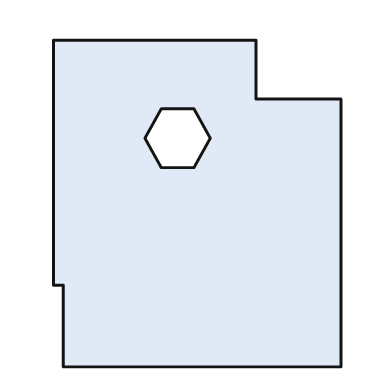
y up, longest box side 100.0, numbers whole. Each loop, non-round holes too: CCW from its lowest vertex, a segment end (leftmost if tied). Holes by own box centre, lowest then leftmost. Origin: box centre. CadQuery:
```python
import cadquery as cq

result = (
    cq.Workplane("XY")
    .moveTo(-41.0, -50.0)
    .lineTo(44.0, -50.0)
    .lineTo(44.0, 32.0)
    .lineTo(18.0, 32.0)
    .lineTo(18.0, 50.0)
    .lineTo(-44.0, 50.0)
    .lineTo(-44.0, -25.0)
    .lineTo(-41.0, -25.0)
    .close()
    .moveTo(-11.0, 11.0)
    .lineTo(-1.0, 11.0)
    .lineTo(4.0, 20.0)
    .lineTo(-1.0, 29.0)
    .lineTo(-11.0, 29.0)
    .lineTo(-16.0, 20.0)
    .close()
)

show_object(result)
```